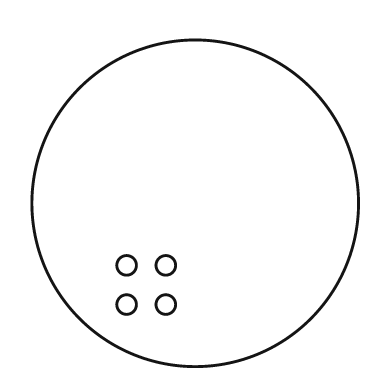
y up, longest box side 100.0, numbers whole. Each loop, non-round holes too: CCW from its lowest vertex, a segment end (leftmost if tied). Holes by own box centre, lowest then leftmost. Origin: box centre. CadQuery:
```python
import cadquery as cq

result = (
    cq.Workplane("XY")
    .moveTo(0.0, 0.0)
    .circle(50.0)
    .moveTo(-21.0, -31.0)
    .circle(3.0)
    .moveTo(-9.0, -31.0)
    .circle(3.0)
    .moveTo(-21.0, -19.0)
    .circle(3.0)
    .moveTo(-9.0, -19.0)
    .circle(3.0)
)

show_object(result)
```